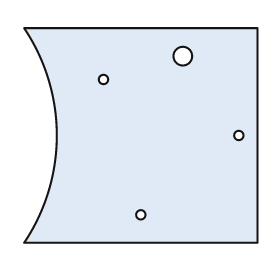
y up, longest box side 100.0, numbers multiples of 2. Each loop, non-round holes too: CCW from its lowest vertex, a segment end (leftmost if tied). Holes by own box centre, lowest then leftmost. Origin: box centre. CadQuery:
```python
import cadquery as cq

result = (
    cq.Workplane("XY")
    .moveTo(-50.0, -46.0)
    .lineTo(50.0, -46.0)
    .lineTo(50.0, 46.0)
    .lineTo(-50.0, 46.0)
    .threePointArc((-36.0, 0.0), (-50.0, -46.0))
    .close()
    .moveTo(0.0, -34.0)
    .circle(2.0)
    .moveTo(42.0, 0.0)
    .circle(2.0)
    .moveTo(-16.0, 24.0)
    .circle(2.0)
    .moveTo(18.0, 34.0)
    .circle(4.0)
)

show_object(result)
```